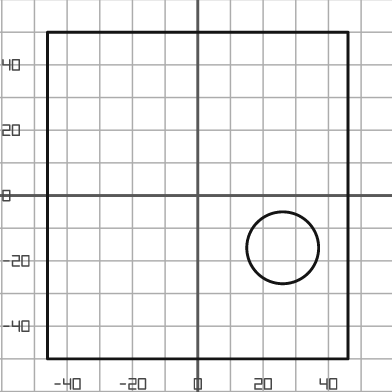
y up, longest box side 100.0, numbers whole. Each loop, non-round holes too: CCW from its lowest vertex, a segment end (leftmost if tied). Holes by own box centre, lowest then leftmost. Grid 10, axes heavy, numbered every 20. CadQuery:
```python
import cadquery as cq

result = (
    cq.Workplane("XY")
    .moveTo(-46.0, -50.0)
    .lineTo(46.0, -50.0)
    .lineTo(46.0, 50.0)
    .lineTo(-46.0, 50.0)
    .close()
    .moveTo(26.0, -16.0)
    .circle(11.0)
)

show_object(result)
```